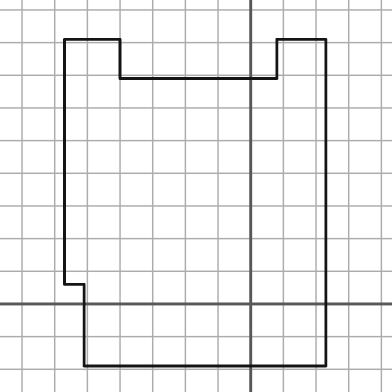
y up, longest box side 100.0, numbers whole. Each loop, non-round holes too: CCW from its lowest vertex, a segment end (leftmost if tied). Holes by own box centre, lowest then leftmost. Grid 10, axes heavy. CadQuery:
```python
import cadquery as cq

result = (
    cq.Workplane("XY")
    .moveTo(-51.0, -19.0)
    .lineTo(23.0, -19.0)
    .lineTo(23.0, 81.0)
    .lineTo(8.0, 81.0)
    .lineTo(8.0, 69.0)
    .lineTo(-40.0, 69.0)
    .lineTo(-40.0, 81.0)
    .lineTo(-57.0, 81.0)
    .lineTo(-57.0, 6.0)
    .lineTo(-51.0, 6.0)
    .close()
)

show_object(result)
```